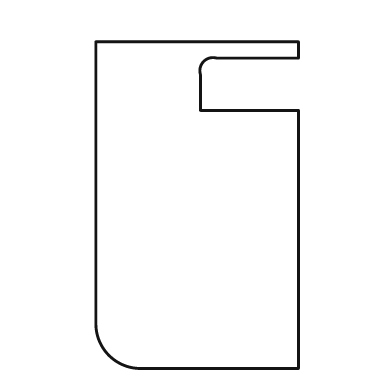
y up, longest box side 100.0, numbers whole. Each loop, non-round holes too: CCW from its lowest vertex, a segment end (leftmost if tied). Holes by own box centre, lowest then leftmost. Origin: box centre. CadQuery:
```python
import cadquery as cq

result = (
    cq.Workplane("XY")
    .moveTo(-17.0, -50.0)
    .lineTo(31.0, -50.0)
    .lineTo(31.0, 29.0)
    .lineTo(1.0, 29.0)
    .lineTo(1.0, 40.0)
    .threePointArc((2.0, 44.0), (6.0, 45.0))
    .lineTo(31.0, 45.0)
    .lineTo(31.0, 50.0)
    .lineTo(-31.0, 50.0)
    .lineTo(-31.0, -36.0)
    .threePointArc((-27.0, -46.0), (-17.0, -50.0))
    .close()
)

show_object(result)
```